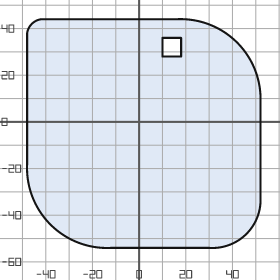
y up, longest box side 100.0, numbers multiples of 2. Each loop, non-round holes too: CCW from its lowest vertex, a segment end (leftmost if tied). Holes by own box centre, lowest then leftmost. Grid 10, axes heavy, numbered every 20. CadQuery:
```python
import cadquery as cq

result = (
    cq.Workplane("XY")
    .moveTo(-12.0, -54.0)
    .lineTo(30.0, -54.0)
    .threePointArc((46.0, -48.0), (52.0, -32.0))
    .lineTo(52.0, 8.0)
    .threePointArc((42.0, 34.0), (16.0, 44.0))
    .lineTo(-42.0, 44.0)
    .threePointArc((-46.0, 42.0), (-48.0, 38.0))
    .lineTo(-48.0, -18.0)
    .threePointArc((-38.0, -44.0), (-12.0, -54.0))
    .close()
    .moveTo(10.0, 28.0)
    .lineTo(18.0, 28.0)
    .lineTo(18.0, 36.0)
    .lineTo(10.0, 36.0)
    .close()
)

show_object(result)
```